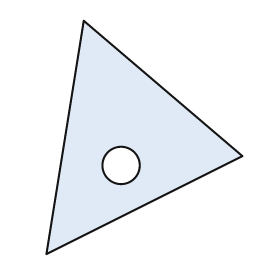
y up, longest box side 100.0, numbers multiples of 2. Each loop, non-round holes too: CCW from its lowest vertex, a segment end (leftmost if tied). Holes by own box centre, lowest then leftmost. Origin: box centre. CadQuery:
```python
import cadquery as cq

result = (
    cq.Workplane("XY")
    .moveTo(-42.0, -50.0)
    .lineTo(42.0, -8.0)
    .lineTo(-26.0, 50.0)
    .close()
    .moveTo(-10.0, -12.0)
    .circle(8.0)
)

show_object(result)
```